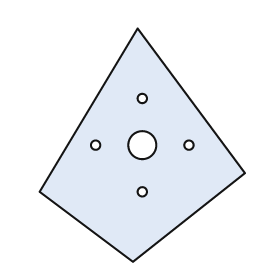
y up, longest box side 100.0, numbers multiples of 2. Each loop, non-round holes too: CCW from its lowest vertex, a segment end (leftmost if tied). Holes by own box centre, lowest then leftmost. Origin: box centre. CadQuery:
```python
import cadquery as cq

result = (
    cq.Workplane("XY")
    .moveTo(-4.0, -50.0)
    .lineTo(44.0, -12.0)
    .lineTo(-2.0, 50.0)
    .lineTo(-44.0, -20.0)
    .close()
    .moveTo(0.0, -20.0)
    .circle(2.0)
    .moveTo(-20.0, 0.0)
    .circle(2.0)
    .moveTo(0.0, 0.0)
    .circle(6.0)
    .moveTo(20.0, 0.0)
    .circle(2.0)
    .moveTo(0.0, 20.0)
    .circle(2.0)
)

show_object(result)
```